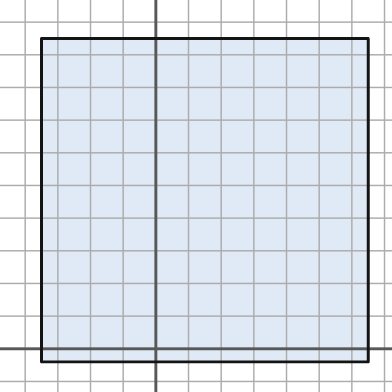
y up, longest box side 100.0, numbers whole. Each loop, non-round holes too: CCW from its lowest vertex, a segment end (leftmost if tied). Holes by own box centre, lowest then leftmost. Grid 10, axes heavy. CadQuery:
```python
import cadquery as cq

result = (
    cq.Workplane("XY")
    .moveTo(-35.0, -4.0)
    .lineTo(65.0, -4.0)
    .lineTo(65.0, 95.0)
    .lineTo(-35.0, 95.0)
    .close()
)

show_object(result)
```